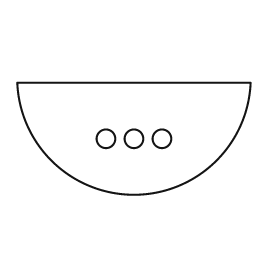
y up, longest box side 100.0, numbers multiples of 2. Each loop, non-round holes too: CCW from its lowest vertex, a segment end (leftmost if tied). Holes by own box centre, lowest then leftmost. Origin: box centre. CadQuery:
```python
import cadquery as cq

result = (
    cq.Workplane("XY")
    .moveTo(-50.0, 24.0)
    .threePointArc((0.0, -24.0), (50.0, 24.0))
    .close()
    .moveTo(-12.0, 0.0)
    .circle(4.0)
    .moveTo(0.0, 0.0)
    .circle(4.0)
    .moveTo(12.0, 0.0)
    .circle(4.0)
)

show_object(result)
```